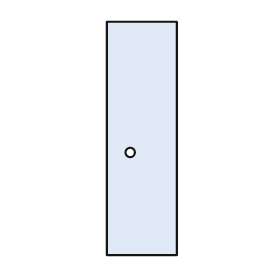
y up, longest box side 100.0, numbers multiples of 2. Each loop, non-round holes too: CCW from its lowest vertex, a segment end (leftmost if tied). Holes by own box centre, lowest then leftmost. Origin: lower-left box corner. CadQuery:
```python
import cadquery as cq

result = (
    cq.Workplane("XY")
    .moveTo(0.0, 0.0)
    .lineTo(30.0, 0.0)
    .lineTo(30.0, 100.0)
    .lineTo(0.0, 100.0)
    .close()
    .moveTo(10.0, 44.0)
    .circle(2.0)
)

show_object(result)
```